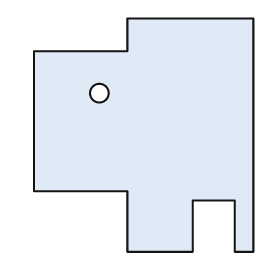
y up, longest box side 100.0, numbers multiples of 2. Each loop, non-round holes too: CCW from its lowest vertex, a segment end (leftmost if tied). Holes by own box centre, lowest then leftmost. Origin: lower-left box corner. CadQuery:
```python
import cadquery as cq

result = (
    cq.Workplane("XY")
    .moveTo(40.0, 0.0)
    .lineTo(68.0, 0.0)
    .lineTo(68.0, 22.0)
    .lineTo(86.0, 22.0)
    .lineTo(86.0, 0.0)
    .lineTo(94.0, 0.0)
    .lineTo(94.0, 100.0)
    .lineTo(40.0, 100.0)
    .lineTo(40.0, 86.0)
    .lineTo(0.0, 86.0)
    .lineTo(0.0, 26.0)
    .lineTo(40.0, 26.0)
    .close()
    .moveTo(28.0, 68.0)
    .circle(4.0)
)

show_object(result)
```